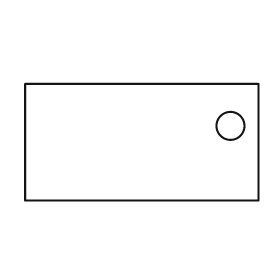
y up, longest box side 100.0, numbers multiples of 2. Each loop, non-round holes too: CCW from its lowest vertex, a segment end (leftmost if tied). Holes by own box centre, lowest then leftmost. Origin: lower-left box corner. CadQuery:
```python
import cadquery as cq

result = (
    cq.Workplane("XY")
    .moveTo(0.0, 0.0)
    .lineTo(100.0, 0.0)
    .lineTo(100.0, 50.0)
    .lineTo(0.0, 50.0)
    .close()
    .moveTo(88.0, 32.0)
    .circle(6.0)
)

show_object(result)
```